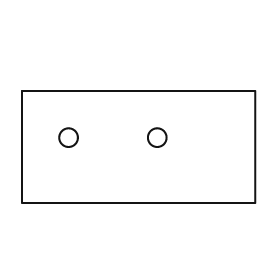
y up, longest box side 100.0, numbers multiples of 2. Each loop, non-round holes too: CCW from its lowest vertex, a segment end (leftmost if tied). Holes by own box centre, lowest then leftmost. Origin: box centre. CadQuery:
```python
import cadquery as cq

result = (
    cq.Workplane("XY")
    .moveTo(-50.0, -24.0)
    .lineTo(50.0, -24.0)
    .lineTo(50.0, 24.0)
    .lineTo(-50.0, 24.0)
    .close()
    .moveTo(-30.0, 4.0)
    .circle(4.0)
    .moveTo(8.0, 4.0)
    .circle(4.0)
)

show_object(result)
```